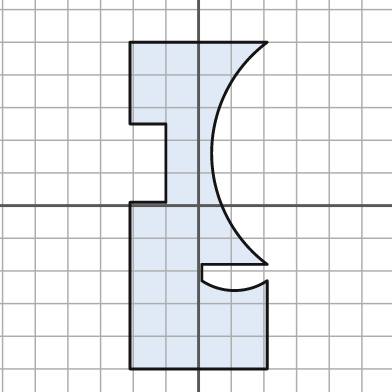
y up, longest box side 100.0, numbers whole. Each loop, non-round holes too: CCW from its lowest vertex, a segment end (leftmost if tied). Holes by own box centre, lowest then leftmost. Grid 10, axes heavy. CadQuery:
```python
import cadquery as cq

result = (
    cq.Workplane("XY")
    .moveTo(-21.0, -50.0)
    .lineTo(21.0, -50.0)
    .lineTo(21.0, -23.0)
    .threePointArc((11.0, -26.0), (1.0, -23.0))
    .lineTo(1.0, -18.0)
    .lineTo(21.0, -18.0)
    .threePointArc((4.0, 16.0), (21.0, 50.0))
    .lineTo(-21.0, 50.0)
    .lineTo(-21.0, 25.0)
    .lineTo(-10.0, 25.0)
    .lineTo(-10.0, 1.0)
    .lineTo(-21.0, 1.0)
    .close()
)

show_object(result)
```